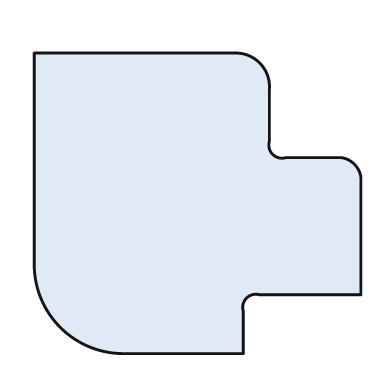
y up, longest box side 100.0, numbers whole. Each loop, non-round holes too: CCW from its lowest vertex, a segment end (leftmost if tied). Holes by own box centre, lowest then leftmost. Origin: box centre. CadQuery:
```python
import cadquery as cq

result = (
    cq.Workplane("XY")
    .moveTo(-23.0, -46.0)
    .lineTo(14.0, -46.0)
    .lineTo(14.0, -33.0)
    .threePointArc((15.0, -29.0), (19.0, -28.0))
    .lineTo(50.0, -28.0)
    .lineTo(50.0, 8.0)
    .threePointArc((48.0, 12.0), (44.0, 14.0))
    .lineTo(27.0, 14.0)
    .threePointArc((23.0, 15.0), (22.0, 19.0))
    .lineTo(22.0, 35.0)
    .threePointArc((19.0, 43.0), (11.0, 46.0))
    .lineTo(-50.0, 46.0)
    .lineTo(-50.0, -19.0)
    .threePointArc((-42.0, -38.0), (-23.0, -46.0))
    .close()
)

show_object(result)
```